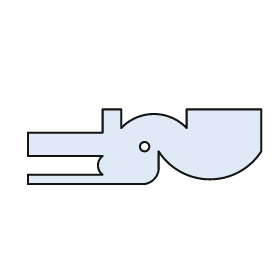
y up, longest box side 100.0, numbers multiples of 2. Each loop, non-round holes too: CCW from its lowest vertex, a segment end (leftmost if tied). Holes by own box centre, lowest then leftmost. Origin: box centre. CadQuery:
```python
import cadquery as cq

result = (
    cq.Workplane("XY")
    .moveTo(-50.0, -16.0)
    .lineTo(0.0, -16.0)
    .threePointArc((4.0, -14.0), (6.0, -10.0))
    .lineTo(6.0, -2.0)
    .threePointArc((28.0, -14.0), (50.0, -2.0))
    .lineTo(50.0, 16.0)
    .lineTo(18.0, 16.0)
    .lineTo(18.0, 8.0)
    .threePointArc((4.0, 14.0), (-10.0, 8.0))
    .lineTo(-10.0, 16.0)
    .lineTo(-18.0, 16.0)
    .lineTo(-18.0, 6.0)
    .lineTo(-50.0, 6.0)
    .lineTo(-50.0, -4.0)
    .lineTo(-18.0, -4.0)
    .threePointArc((-20.0, -8.0), (-18.0, -12.0))
    .lineTo(-50.0, -12.0)
    .close()
    .moveTo(0.0, 0.0)
    .circle(2.0)
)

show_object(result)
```